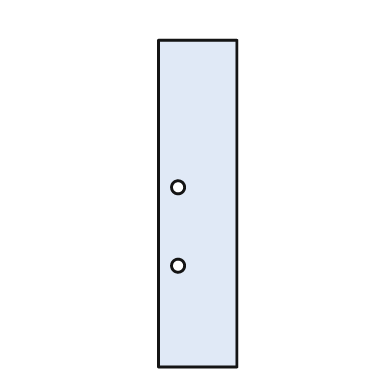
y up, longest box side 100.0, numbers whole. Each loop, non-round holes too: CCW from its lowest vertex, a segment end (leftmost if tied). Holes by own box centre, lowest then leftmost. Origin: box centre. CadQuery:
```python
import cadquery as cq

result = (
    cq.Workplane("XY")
    .moveTo(-12.0, -50.0)
    .lineTo(12.0, -50.0)
    .lineTo(12.0, 50.0)
    .lineTo(-12.0, 50.0)
    .close()
    .moveTo(-6.0, -19.0)
    .circle(2.0)
    .moveTo(-6.0, 5.0)
    .circle(2.0)
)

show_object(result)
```